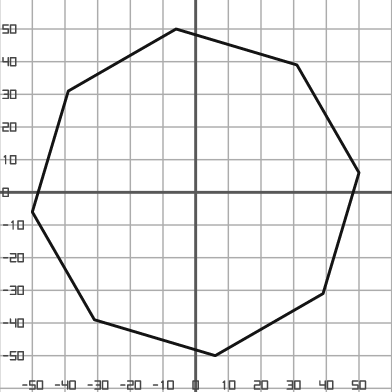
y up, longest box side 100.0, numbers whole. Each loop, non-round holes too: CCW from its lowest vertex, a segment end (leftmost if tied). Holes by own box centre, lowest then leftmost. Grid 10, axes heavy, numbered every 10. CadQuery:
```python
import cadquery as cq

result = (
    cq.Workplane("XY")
    .moveTo(6.0, -50.0)
    .lineTo(39.0, -31.0)
    .lineTo(50.0, 6.0)
    .lineTo(31.0, 39.0)
    .lineTo(-6.0, 50.0)
    .lineTo(-39.0, 31.0)
    .lineTo(-50.0, -6.0)
    .lineTo(-31.0, -39.0)
    .close()
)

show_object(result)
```